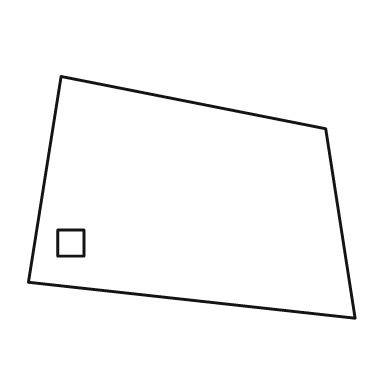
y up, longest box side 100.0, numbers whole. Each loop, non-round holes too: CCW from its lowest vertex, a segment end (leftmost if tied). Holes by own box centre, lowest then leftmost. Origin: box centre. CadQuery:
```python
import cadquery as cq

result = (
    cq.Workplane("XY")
    .moveTo(50.0, -37.0)
    .lineTo(41.0, 21.0)
    .lineTo(-40.0, 37.0)
    .lineTo(-50.0, -26.0)
    .close()
    .moveTo(-41.0, -18.0)
    .lineTo(-33.0, -18.0)
    .lineTo(-33.0, -10.0)
    .lineTo(-41.0, -10.0)
    .close()
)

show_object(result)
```